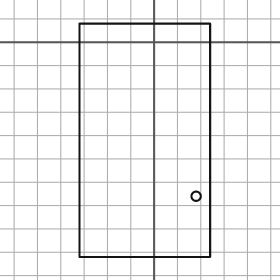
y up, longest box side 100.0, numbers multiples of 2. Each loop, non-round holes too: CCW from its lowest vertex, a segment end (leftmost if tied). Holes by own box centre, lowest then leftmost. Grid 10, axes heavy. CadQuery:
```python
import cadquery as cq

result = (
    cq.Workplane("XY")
    .moveTo(-32.0, -92.0)
    .lineTo(24.0, -92.0)
    .lineTo(24.0, 8.0)
    .lineTo(-32.0, 8.0)
    .close()
    .moveTo(18.0, -66.0)
    .circle(2.0)
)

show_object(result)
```